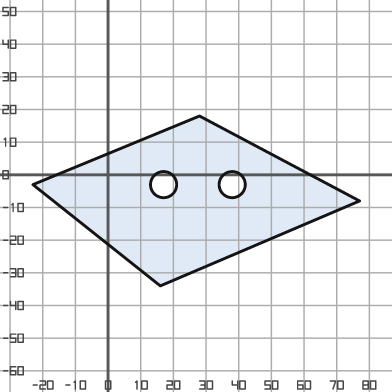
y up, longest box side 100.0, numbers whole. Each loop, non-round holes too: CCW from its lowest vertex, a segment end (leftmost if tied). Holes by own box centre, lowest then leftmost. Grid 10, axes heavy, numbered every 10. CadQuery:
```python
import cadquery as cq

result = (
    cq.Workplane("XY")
    .moveTo(16.0, -34.0)
    .lineTo(77.0, -8.0)
    .lineTo(28.0, 18.0)
    .lineTo(-23.0, -3.0)
    .close()
    .moveTo(17.0, -3.0)
    .circle(4.0)
    .moveTo(38.0, -3.0)
    .circle(4.0)
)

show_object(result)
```